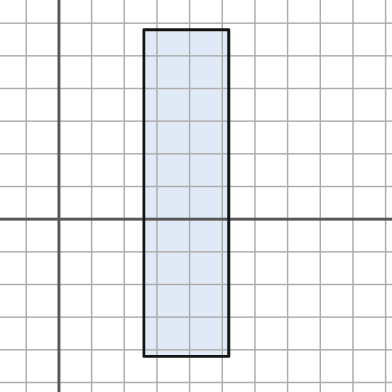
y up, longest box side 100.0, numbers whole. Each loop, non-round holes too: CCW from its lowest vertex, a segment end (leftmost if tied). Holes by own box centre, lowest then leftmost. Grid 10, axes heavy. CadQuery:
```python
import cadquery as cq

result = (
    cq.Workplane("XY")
    .moveTo(26.0, -42.0)
    .lineTo(52.0, -42.0)
    .lineTo(52.0, 58.0)
    .lineTo(26.0, 58.0)
    .close()
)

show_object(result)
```